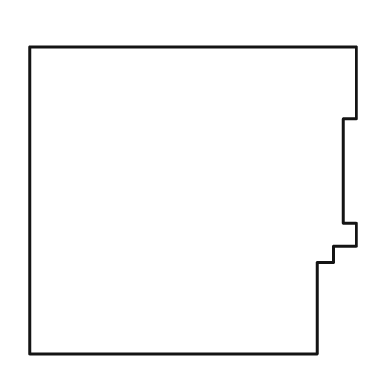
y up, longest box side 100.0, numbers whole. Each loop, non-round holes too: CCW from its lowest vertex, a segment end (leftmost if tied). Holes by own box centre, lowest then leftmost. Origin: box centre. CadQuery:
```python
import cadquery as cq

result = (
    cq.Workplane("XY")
    .moveTo(-50.0, -47.0)
    .lineTo(38.0, -47.0)
    .lineTo(38.0, -19.0)
    .lineTo(43.0, -19.0)
    .lineTo(43.0, -14.0)
    .lineTo(50.0, -14.0)
    .lineTo(50.0, -7.0)
    .lineTo(46.0, -7.0)
    .lineTo(46.0, 25.0)
    .lineTo(50.0, 25.0)
    .lineTo(50.0, 47.0)
    .lineTo(-50.0, 47.0)
    .close()
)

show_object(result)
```